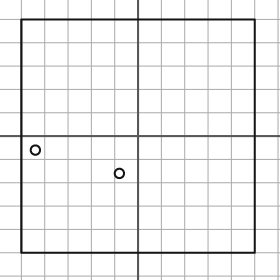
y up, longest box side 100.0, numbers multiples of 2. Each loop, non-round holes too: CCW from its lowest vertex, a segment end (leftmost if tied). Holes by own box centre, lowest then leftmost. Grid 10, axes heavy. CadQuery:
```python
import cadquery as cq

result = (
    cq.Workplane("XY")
    .moveTo(-50.0, -50.0)
    .lineTo(50.0, -50.0)
    .lineTo(50.0, 50.0)
    .lineTo(-50.0, 50.0)
    .close()
    .moveTo(-8.0, -16.0)
    .circle(2.0)
    .moveTo(-44.0, -6.0)
    .circle(2.0)
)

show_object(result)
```